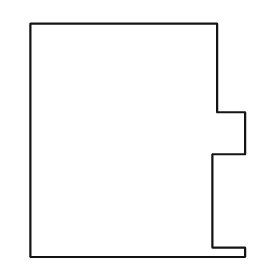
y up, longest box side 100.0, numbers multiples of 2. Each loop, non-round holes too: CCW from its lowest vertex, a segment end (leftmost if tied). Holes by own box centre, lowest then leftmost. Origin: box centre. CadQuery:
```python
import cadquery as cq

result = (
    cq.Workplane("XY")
    .moveTo(-46.0, -50.0)
    .lineTo(46.0, -50.0)
    .lineTo(46.0, -46.0)
    .lineTo(32.0, -46.0)
    .lineTo(32.0, -6.0)
    .lineTo(46.0, -6.0)
    .lineTo(46.0, 12.0)
    .lineTo(34.0, 12.0)
    .lineTo(34.0, 50.0)
    .lineTo(-46.0, 50.0)
    .close()
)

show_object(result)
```